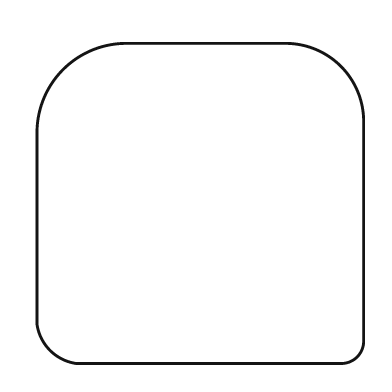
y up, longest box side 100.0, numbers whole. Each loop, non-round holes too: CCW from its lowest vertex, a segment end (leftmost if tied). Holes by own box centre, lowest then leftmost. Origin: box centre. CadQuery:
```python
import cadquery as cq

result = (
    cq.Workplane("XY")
    .moveTo(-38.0, -49.0)
    .lineTo(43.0, -49.0)
    .threePointArc((48.0, -47.0), (50.0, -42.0))
    .lineTo(50.0, 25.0)
    .threePointArc((43.0, 42.0), (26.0, 49.0))
    .lineTo(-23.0, 49.0)
    .threePointArc((-42.0, 41.0), (-50.0, 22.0))
    .lineTo(-50.0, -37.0)
    .threePointArc((-46.0, -45.0), (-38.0, -49.0))
    .close()
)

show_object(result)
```